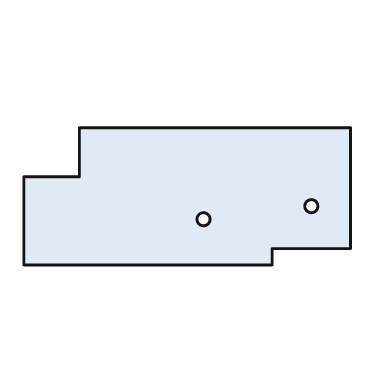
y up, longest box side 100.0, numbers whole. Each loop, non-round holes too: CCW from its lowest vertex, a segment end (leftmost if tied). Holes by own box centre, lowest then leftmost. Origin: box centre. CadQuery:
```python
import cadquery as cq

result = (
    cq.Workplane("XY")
    .moveTo(-50.0, -21.0)
    .lineTo(26.0, -21.0)
    .lineTo(26.0, -16.0)
    .lineTo(50.0, -16.0)
    .lineTo(50.0, 21.0)
    .lineTo(-33.0, 21.0)
    .lineTo(-33.0, 6.0)
    .lineTo(-50.0, 6.0)
    .close()
    .moveTo(5.0, -7.0)
    .circle(2.0)
    .moveTo(38.0, -3.0)
    .circle(2.0)
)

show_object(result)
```